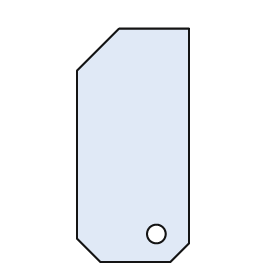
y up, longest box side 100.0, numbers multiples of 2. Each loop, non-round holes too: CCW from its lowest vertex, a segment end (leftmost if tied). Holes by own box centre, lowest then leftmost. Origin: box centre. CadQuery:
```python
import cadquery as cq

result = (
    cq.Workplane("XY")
    .moveTo(-14.0, -50.0)
    .lineTo(16.0, -50.0)
    .lineTo(24.0, -42.0)
    .lineTo(24.0, 50.0)
    .lineTo(-6.0, 50.0)
    .lineTo(-24.0, 32.0)
    .lineTo(-24.0, -40.0)
    .close()
    .moveTo(10.0, -38.0)
    .circle(4.0)
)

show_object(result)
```